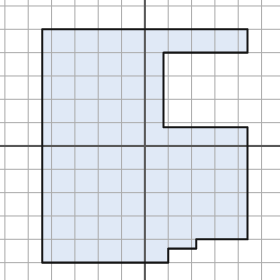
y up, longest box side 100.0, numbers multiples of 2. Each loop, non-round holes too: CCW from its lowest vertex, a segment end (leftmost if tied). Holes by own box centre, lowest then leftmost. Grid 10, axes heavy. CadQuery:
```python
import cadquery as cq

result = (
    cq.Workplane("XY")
    .moveTo(-44.0, -50.0)
    .lineTo(10.0, -50.0)
    .lineTo(10.0, -44.0)
    .lineTo(22.0, -44.0)
    .lineTo(22.0, -40.0)
    .lineTo(44.0, -40.0)
    .lineTo(44.0, 8.0)
    .lineTo(8.0, 8.0)
    .lineTo(8.0, 40.0)
    .lineTo(44.0, 40.0)
    .lineTo(44.0, 50.0)
    .lineTo(-44.0, 50.0)
    .close()
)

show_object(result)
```